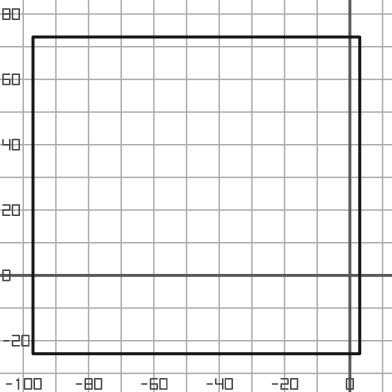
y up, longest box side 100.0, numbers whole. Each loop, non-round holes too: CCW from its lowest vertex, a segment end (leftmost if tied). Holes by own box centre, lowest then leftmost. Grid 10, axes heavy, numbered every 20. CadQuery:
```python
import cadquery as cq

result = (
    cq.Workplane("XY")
    .moveTo(-97.0, -24.0)
    .lineTo(3.0, -24.0)
    .lineTo(3.0, 73.0)
    .lineTo(-97.0, 73.0)
    .close()
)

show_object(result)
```